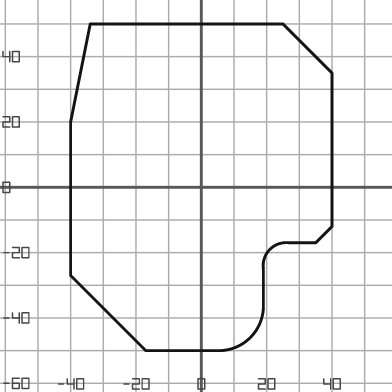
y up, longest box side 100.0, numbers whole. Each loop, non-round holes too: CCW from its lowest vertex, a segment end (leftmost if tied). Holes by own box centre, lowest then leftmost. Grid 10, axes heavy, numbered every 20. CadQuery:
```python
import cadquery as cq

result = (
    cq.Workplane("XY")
    .moveTo(-17.0, -50.0)
    .lineTo(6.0, -50.0)
    .threePointArc((15.0, -46.0), (19.0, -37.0))
    .lineTo(19.0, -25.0)
    .threePointArc((21.0, -19.0), (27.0, -17.0))
    .lineTo(35.0, -17.0)
    .lineTo(40.0, -12.0)
    .lineTo(40.0, 35.0)
    .lineTo(25.0, 50.0)
    .lineTo(-34.0, 50.0)
    .lineTo(-40.0, 20.0)
    .lineTo(-40.0, -27.0)
    .close()
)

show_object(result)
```